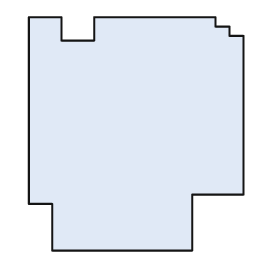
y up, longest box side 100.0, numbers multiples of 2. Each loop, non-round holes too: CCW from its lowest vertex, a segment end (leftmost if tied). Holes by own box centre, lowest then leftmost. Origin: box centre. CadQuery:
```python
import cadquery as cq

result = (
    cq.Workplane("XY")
    .moveTo(-36.0, -50.0)
    .lineTo(24.0, -50.0)
    .lineTo(24.0, -26.0)
    .lineTo(46.0, -26.0)
    .lineTo(46.0, 42.0)
    .lineTo(40.0, 42.0)
    .lineTo(40.0, 46.0)
    .lineTo(34.0, 46.0)
    .lineTo(34.0, 50.0)
    .lineTo(-18.0, 50.0)
    .lineTo(-18.0, 40.0)
    .lineTo(-32.0, 40.0)
    .lineTo(-32.0, 50.0)
    .lineTo(-46.0, 50.0)
    .lineTo(-46.0, -30.0)
    .lineTo(-36.0, -30.0)
    .close()
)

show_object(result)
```